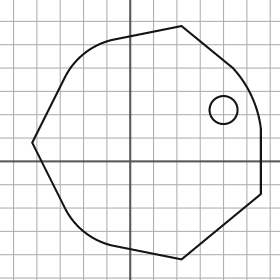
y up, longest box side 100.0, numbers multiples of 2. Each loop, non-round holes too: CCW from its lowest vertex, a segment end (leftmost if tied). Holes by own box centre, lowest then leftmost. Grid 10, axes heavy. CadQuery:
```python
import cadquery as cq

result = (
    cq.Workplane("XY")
    .moveTo(22.0, -42.0)
    .lineTo(56.0, -14.0)
    .lineTo(56.0, 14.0)
    .threePointArc((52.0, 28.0), (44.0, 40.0))
    .lineTo(22.0, 58.0)
    .lineTo(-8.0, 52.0)
    .threePointArc((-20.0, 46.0), (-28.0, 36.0))
    .lineTo(-42.0, 8.0)
    .lineTo(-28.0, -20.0)
    .threePointArc((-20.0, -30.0), (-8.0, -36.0))
    .close()
    .moveTo(40.0, 22.0)
    .circle(6.0)
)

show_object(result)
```